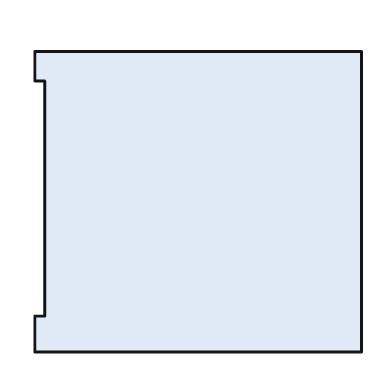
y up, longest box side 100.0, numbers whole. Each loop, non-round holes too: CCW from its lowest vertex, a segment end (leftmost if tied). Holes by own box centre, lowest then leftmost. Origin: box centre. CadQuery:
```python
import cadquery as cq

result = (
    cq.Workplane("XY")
    .moveTo(-50.0, -46.0)
    .lineTo(50.0, -46.0)
    .lineTo(50.0, 46.0)
    .lineTo(-50.0, 46.0)
    .lineTo(-50.0, 37.0)
    .lineTo(-47.0, 37.0)
    .lineTo(-47.0, -35.0)
    .lineTo(-50.0, -35.0)
    .close()
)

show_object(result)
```